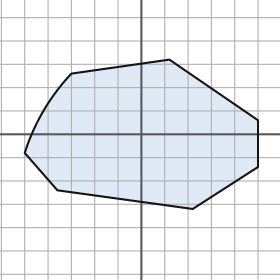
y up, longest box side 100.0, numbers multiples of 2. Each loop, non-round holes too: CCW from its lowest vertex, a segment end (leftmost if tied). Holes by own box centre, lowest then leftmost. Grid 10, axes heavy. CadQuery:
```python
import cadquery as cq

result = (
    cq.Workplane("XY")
    .moveTo(22.0, -32.0)
    .lineTo(50.0, -14.0)
    .lineTo(50.0, 6.0)
    .lineTo(12.0, 32.0)
    .lineTo(-30.0, 26.0)
    .threePointArc((-42.0, 10.0), (-50.0, -8.0))
    .lineTo(-36.0, -24.0)
    .close()
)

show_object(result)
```